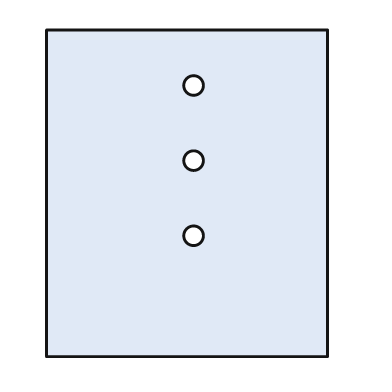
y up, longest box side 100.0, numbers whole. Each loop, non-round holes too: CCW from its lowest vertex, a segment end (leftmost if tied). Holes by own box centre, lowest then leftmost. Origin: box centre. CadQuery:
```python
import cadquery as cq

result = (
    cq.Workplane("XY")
    .moveTo(-43.0, -50.0)
    .lineTo(43.0, -50.0)
    .lineTo(43.0, 50.0)
    .lineTo(-43.0, 50.0)
    .close()
    .moveTo(2.0, -13.0)
    .circle(3.0)
    .moveTo(2.0, 10.0)
    .circle(3.0)
    .moveTo(2.0, 33.0)
    .circle(3.0)
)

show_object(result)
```